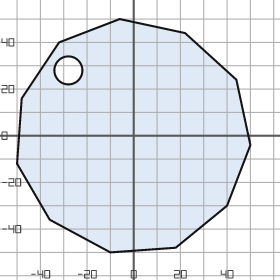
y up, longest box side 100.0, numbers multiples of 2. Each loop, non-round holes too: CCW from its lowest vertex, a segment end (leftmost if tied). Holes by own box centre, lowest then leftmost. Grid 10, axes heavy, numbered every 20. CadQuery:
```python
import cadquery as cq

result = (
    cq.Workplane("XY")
    .moveTo(-10.0, -50.0)
    .lineTo(18.0, -48.0)
    .lineTo(40.0, -30.0)
    .lineTo(50.0, -4.0)
    .lineTo(44.0, 24.0)
    .lineTo(22.0, 44.0)
    .lineTo(-6.0, 50.0)
    .lineTo(-32.0, 40.0)
    .lineTo(-48.0, 16.0)
    .lineTo(-50.0, -12.0)
    .lineTo(-36.0, -36.0)
    .close()
    .moveTo(-28.0, 28.0)
    .circle(6.0)
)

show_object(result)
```